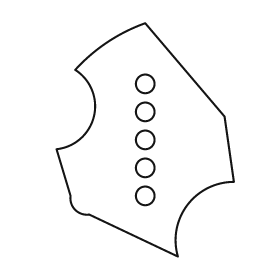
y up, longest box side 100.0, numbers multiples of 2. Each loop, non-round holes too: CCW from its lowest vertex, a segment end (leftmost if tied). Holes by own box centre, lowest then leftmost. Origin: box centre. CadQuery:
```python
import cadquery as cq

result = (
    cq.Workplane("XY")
    .moveTo(14.0, -50.0)
    .threePointArc((18.0, -28.0), (38.0, -18.0))
    .lineTo(34.0, 10.0)
    .lineTo(0.0, 50.0)
    .threePointArc((-16.0, 42.0), (-30.0, 30.0))
    .threePointArc((-22.0, 10.0), (-38.0, -4.0))
    .lineTo(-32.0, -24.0)
    .threePointArc((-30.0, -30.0), (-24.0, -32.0))
    .close()
    .moveTo(0.0, -24.0)
    .circle(4.0)
    .moveTo(0.0, -12.0)
    .circle(4.0)
    .moveTo(0.0, 0.0)
    .circle(4.0)
    .moveTo(0.0, 12.0)
    .circle(4.0)
    .moveTo(0.0, 24.0)
    .circle(4.0)
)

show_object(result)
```